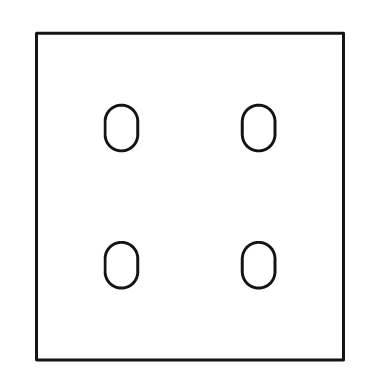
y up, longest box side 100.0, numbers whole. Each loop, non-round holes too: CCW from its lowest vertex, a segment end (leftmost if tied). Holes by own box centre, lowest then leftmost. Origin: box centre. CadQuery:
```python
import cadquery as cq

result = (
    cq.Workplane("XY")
    .moveTo(-47.0, -50.0)
    .lineTo(47.0, -50.0)
    .lineTo(47.0, 50.0)
    .lineTo(-47.0, 50.0)
    .close()
    .moveTo(-26.0, -23.0)
    .threePointArc((-21.0, -28.0), (-16.0, -23.0))
    .lineTo(-16.0, -19.0)
    .threePointArc((-21.0, -14.0), (-26.0, -19.0))
    .close()
    .moveTo(16.0, -23.0)
    .threePointArc((21.0, -28.0), (26.0, -23.0))
    .lineTo(26.0, -19.0)
    .threePointArc((21.0, -14.0), (16.0, -19.0))
    .close()
    .moveTo(-26.0, 19.0)
    .threePointArc((-21.0, 14.0), (-16.0, 19.0))
    .lineTo(-16.0, 23.0)
    .threePointArc((-21.0, 28.0), (-26.0, 23.0))
    .close()
    .moveTo(16.0, 19.0)
    .threePointArc((21.0, 14.0), (26.0, 19.0))
    .lineTo(26.0, 23.0)
    .threePointArc((21.0, 28.0), (16.0, 23.0))
    .close()
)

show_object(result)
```